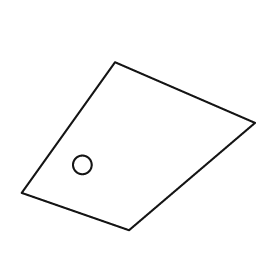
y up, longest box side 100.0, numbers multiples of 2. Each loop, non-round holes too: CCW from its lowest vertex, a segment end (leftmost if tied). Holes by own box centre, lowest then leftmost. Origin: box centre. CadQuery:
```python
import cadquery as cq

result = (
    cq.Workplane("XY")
    .moveTo(-4.0, -36.0)
    .lineTo(50.0, 10.0)
    .lineTo(-10.0, 36.0)
    .lineTo(-50.0, -20.0)
    .close()
    .moveTo(-24.0, -8.0)
    .circle(4.0)
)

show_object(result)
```